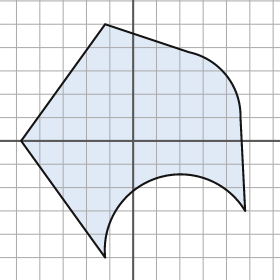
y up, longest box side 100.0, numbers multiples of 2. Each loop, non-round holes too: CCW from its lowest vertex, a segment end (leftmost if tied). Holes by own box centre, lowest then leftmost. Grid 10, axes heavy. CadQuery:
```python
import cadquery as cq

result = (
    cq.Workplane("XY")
    .moveTo(-12.0, -50.0)
    .threePointArc((10.0, -16.0), (48.0, -30.0))
    .lineTo(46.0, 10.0)
    .threePointArc((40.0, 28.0), (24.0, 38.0))
    .lineTo(-12.0, 50.0)
    .lineTo(-48.0, 0.0)
    .close()
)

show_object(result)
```